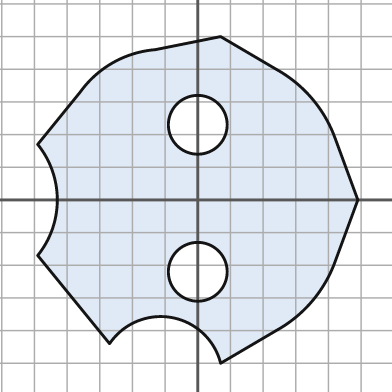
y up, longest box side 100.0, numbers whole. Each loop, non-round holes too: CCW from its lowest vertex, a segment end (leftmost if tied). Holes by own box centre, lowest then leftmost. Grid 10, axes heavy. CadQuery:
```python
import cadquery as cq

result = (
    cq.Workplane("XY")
    .moveTo(7.0, -50.0)
    .lineTo(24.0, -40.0)
    .threePointArc((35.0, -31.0), (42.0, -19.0))
    .lineTo(49.0, 0.0)
    .lineTo(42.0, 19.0)
    .threePointArc((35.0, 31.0), (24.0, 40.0))
    .lineTo(7.0, 50.0)
    .lineTo(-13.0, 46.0)
    .threePointArc((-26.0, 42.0), (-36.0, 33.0))
    .lineTo(-49.0, 17.0)
    .threePointArc((-43.0, 0.0), (-49.0, -17.0))
    .lineTo(-27.0, -44.0)
    .threePointArc((-8.0, -36.0), (7.0, -50.0))
    .close()
    .moveTo(0.0, -22.0)
    .circle(9.0)
    .moveTo(0.0, 23.0)
    .circle(9.0)
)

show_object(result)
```